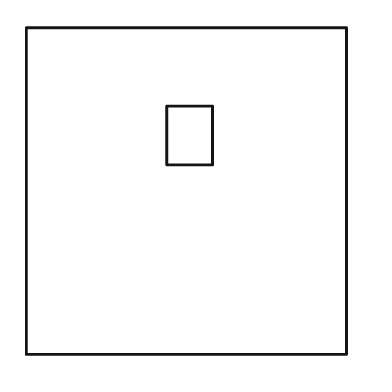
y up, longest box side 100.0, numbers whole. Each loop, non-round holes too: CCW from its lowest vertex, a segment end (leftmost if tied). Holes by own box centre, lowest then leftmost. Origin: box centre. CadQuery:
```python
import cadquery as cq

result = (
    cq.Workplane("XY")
    .moveTo(-49.0, -50.0)
    .lineTo(49.0, -50.0)
    .lineTo(49.0, 50.0)
    .lineTo(-49.0, 50.0)
    .close()
    .moveTo(-6.0, 8.0)
    .lineTo(8.0, 8.0)
    .lineTo(8.0, 26.0)
    .lineTo(-6.0, 26.0)
    .close()
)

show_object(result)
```